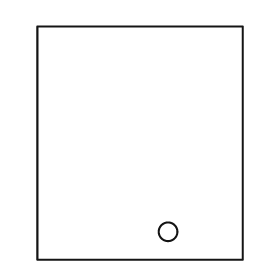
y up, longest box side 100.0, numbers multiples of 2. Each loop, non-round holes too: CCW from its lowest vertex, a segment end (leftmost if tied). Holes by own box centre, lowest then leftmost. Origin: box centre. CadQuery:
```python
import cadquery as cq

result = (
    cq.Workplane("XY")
    .moveTo(-44.0, -50.0)
    .lineTo(44.0, -50.0)
    .lineTo(44.0, 50.0)
    .lineTo(-44.0, 50.0)
    .close()
    .moveTo(12.0, -38.0)
    .circle(4.0)
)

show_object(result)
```